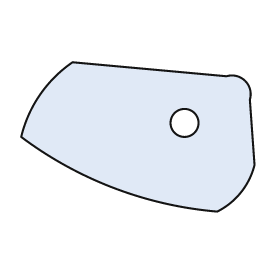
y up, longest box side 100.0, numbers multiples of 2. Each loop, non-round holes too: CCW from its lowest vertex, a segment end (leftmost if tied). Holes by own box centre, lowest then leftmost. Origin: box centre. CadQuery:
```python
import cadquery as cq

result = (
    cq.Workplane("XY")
    .moveTo(34.0, -32.0)
    .threePointArc((44.0, -24.0), (50.0, -12.0))
    .lineTo(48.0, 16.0)
    .threePointArc((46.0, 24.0), (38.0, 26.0))
    .lineTo(-28.0, 32.0)
    .threePointArc((-42.0, 18.0), (-50.0, 0.0))
    .threePointArc((-10.0, -22.0), (34.0, -32.0))
    .close()
    .moveTo(20.0, 6.0)
    .circle(6.0)
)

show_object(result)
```